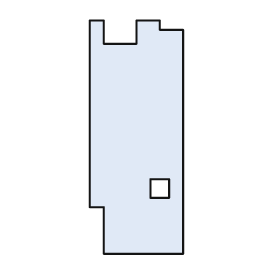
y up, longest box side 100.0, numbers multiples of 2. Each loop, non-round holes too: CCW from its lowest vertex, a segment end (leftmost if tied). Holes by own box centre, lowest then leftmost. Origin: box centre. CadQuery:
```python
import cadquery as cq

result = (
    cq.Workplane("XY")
    .moveTo(-14.0, -50.0)
    .lineTo(20.0, -50.0)
    .lineTo(20.0, 46.0)
    .lineTo(10.0, 46.0)
    .lineTo(10.0, 50.0)
    .lineTo(0.0, 50.0)
    .lineTo(0.0, 40.0)
    .lineTo(-14.0, 40.0)
    .lineTo(-14.0, 50.0)
    .lineTo(-20.0, 50.0)
    .lineTo(-20.0, -30.0)
    .lineTo(-14.0, -30.0)
    .close()
    .moveTo(6.0, -26.0)
    .lineTo(14.0, -26.0)
    .lineTo(14.0, -18.0)
    .lineTo(6.0, -18.0)
    .close()
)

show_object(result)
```